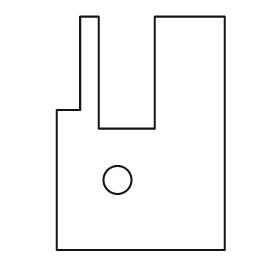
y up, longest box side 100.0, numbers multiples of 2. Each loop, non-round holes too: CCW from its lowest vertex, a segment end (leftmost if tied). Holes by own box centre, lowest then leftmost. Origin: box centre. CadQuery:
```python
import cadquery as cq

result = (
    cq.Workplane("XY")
    .moveTo(-36.0, -50.0)
    .lineTo(36.0, -50.0)
    .lineTo(36.0, 50.0)
    .lineTo(6.0, 50.0)
    .lineTo(6.0, 2.0)
    .lineTo(-18.0, 2.0)
    .lineTo(-18.0, 50.0)
    .lineTo(-26.0, 50.0)
    .lineTo(-26.0, 10.0)
    .lineTo(-36.0, 10.0)
    .close()
    .moveTo(-10.0, -20.0)
    .circle(6.0)
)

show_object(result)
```